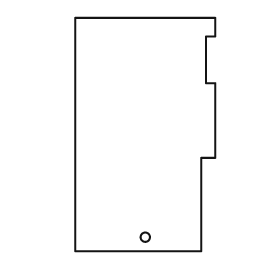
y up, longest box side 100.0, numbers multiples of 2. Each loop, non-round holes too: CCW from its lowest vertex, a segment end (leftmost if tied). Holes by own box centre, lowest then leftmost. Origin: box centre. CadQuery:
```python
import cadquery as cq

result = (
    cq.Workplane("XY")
    .moveTo(-30.0, -50.0)
    .lineTo(24.0, -50.0)
    .lineTo(24.0, -10.0)
    .lineTo(30.0, -10.0)
    .lineTo(30.0, 22.0)
    .lineTo(26.0, 22.0)
    .lineTo(26.0, 42.0)
    .lineTo(30.0, 42.0)
    .lineTo(30.0, 50.0)
    .lineTo(-30.0, 50.0)
    .close()
    .moveTo(0.0, -44.0)
    .circle(2.0)
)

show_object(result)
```